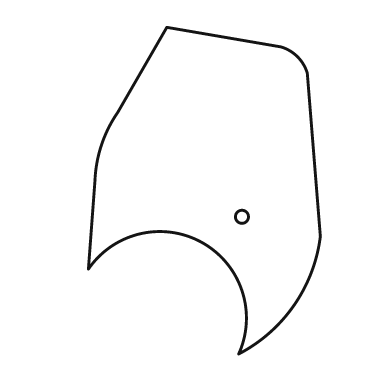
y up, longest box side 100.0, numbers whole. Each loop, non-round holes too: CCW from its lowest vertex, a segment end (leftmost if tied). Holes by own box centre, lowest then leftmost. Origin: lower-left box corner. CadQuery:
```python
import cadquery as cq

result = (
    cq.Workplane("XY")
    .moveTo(46.0, 0.0)
    .threePointArc((63.0, 15.0), (71.0, 36.0))
    .lineTo(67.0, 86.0)
    .threePointArc((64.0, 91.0), (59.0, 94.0))
    .lineTo(24.0, 100.0)
    .lineTo(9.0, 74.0)
    .threePointArc((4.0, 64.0), (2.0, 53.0))
    .lineTo(0.0, 26.0)
    .threePointArc((35.0, 34.0), (46.0, 0.0))
    .close()
    .moveTo(47.0, 42.0)
    .circle(2.0)
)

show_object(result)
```